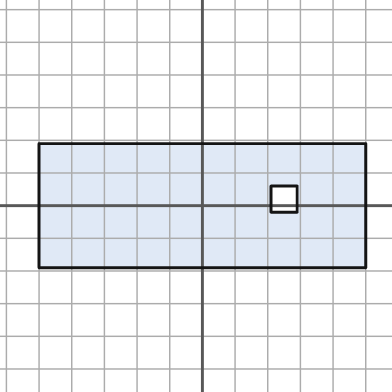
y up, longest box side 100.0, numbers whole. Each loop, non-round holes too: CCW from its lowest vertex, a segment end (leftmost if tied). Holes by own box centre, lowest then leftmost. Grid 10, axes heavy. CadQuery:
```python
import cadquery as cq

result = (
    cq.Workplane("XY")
    .moveTo(-50.0, -19.0)
    .lineTo(50.0, -19.0)
    .lineTo(50.0, 19.0)
    .lineTo(-50.0, 19.0)
    .close()
    .moveTo(21.0, -2.0)
    .lineTo(29.0, -2.0)
    .lineTo(29.0, 6.0)
    .lineTo(21.0, 6.0)
    .close()
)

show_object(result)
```